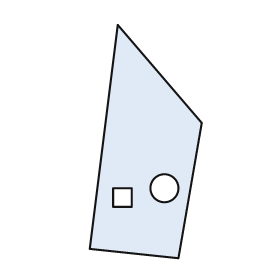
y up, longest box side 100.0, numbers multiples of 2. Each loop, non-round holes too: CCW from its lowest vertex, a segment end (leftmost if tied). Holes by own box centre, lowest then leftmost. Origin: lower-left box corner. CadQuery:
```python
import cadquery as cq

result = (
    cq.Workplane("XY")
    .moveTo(38.0, 0.0)
    .lineTo(48.0, 58.0)
    .lineTo(12.0, 100.0)
    .lineTo(0.0, 4.0)
    .close()
    .moveTo(10.0, 22.0)
    .lineTo(18.0, 22.0)
    .lineTo(18.0, 30.0)
    .lineTo(10.0, 30.0)
    .close()
    .moveTo(32.0, 30.0)
    .circle(6.0)
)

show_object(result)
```